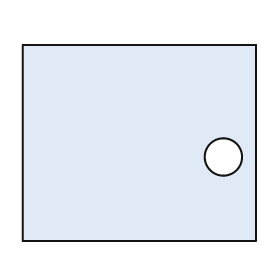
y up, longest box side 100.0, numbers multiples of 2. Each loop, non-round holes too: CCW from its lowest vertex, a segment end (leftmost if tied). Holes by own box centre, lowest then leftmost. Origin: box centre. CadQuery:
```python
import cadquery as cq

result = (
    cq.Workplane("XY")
    .moveTo(-50.0, -42.0)
    .lineTo(50.0, -42.0)
    .lineTo(50.0, 42.0)
    .lineTo(-50.0, 42.0)
    .close()
    .moveTo(36.0, -6.0)
    .circle(8.0)
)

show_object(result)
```